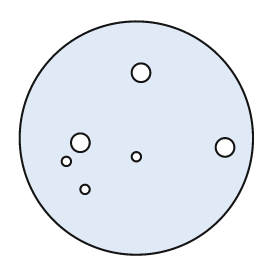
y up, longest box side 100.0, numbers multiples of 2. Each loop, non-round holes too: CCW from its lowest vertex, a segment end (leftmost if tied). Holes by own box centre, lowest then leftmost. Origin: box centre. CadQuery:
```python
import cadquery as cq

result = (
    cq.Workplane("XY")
    .moveTo(0.0, 0.0)
    .circle(50.0)
    .moveTo(-22.0, -22.0)
    .circle(2.0)
    .moveTo(-30.0, -10.0)
    .circle(2.0)
    .moveTo(0.0, -8.0)
    .circle(2.0)
    .moveTo(38.0, -4.0)
    .circle(4.0)
    .moveTo(-24.0, -2.0)
    .circle(4.0)
    .moveTo(2.0, 28.0)
    .circle(4.0)
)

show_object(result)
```